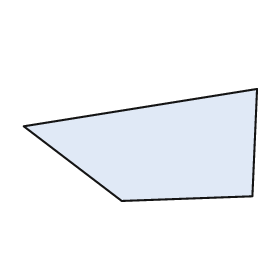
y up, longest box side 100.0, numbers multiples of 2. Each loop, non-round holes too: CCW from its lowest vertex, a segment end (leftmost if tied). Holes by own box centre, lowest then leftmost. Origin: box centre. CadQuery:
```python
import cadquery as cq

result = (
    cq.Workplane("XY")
    .moveTo(-8.0, -24.0)
    .lineTo(48.0, -22.0)
    .lineTo(50.0, 24.0)
    .lineTo(-50.0, 8.0)
    .close()
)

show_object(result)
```